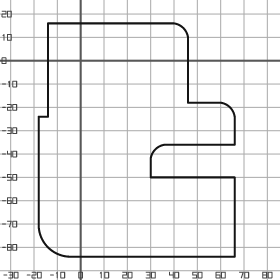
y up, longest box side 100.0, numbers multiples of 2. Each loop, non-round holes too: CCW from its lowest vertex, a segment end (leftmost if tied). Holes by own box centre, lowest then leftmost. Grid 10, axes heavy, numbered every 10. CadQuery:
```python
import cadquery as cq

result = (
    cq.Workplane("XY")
    .moveTo(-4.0, -84.0)
    .lineTo(66.0, -84.0)
    .lineTo(66.0, -50.0)
    .lineTo(30.0, -50.0)
    .lineTo(30.0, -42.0)
    .threePointArc((32.0, -38.0), (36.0, -36.0))
    .lineTo(66.0, -36.0)
    .lineTo(66.0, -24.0)
    .threePointArc((64.0, -20.0), (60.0, -18.0))
    .lineTo(46.0, -18.0)
    .lineTo(46.0, 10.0)
    .threePointArc((44.0, 14.0), (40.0, 16.0))
    .lineTo(-14.0, 16.0)
    .lineTo(-14.0, -24.0)
    .lineTo(-18.0, -24.0)
    .lineTo(-18.0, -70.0)
    .threePointArc((-14.0, -80.0), (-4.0, -84.0))
    .close()
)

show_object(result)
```